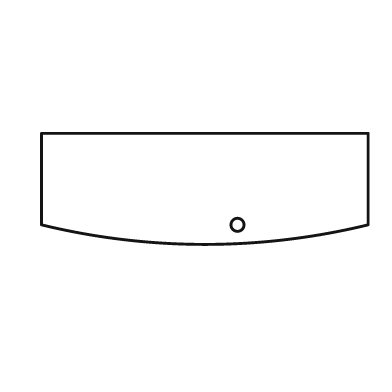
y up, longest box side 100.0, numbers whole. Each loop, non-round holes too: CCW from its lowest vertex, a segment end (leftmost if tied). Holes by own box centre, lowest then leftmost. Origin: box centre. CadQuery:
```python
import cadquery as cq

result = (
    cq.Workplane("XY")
    .moveTo(-50.0, -11.0)
    .threePointArc((0.0, -17.0), (50.0, -11.0))
    .lineTo(50.0, 17.0)
    .lineTo(-50.0, 17.0)
    .close()
    .moveTo(10.0, -11.0)
    .circle(2.0)
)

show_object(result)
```